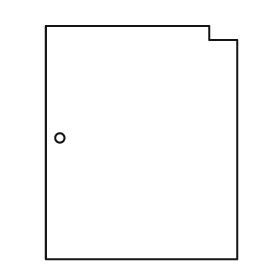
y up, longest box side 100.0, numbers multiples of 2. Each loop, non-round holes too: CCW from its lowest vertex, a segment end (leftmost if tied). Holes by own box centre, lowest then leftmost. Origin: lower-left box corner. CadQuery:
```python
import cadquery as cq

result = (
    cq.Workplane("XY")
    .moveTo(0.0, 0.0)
    .lineTo(82.0, 0.0)
    .lineTo(82.0, 94.0)
    .lineTo(70.0, 94.0)
    .lineTo(70.0, 100.0)
    .lineTo(0.0, 100.0)
    .close()
    .moveTo(6.0, 52.0)
    .circle(2.0)
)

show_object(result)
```